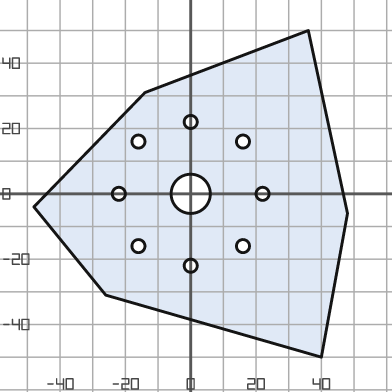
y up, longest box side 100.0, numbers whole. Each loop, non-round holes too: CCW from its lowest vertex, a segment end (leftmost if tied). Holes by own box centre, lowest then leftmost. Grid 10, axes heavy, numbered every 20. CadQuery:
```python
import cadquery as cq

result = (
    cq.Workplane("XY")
    .moveTo(40.0, -50.0)
    .lineTo(48.0, -6.0)
    .lineTo(36.0, 50.0)
    .lineTo(-14.0, 31.0)
    .lineTo(-48.0, -4.0)
    .lineTo(-26.0, -31.0)
    .close()
    .moveTo(0.0, -22.0)
    .circle(2.0)
    .moveTo(-16.0, -16.0)
    .circle(2.0)
    .moveTo(16.0, -16.0)
    .circle(2.0)
    .moveTo(-22.0, 0.0)
    .circle(2.0)
    .moveTo(0.0, 0.0)
    .circle(6.0)
    .moveTo(22.0, 0.0)
    .circle(2.0)
    .moveTo(-16.0, 16.0)
    .circle(2.0)
    .moveTo(16.0, 16.0)
    .circle(2.0)
    .moveTo(0.0, 22.0)
    .circle(2.0)
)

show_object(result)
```